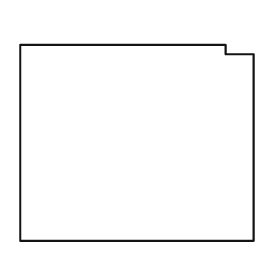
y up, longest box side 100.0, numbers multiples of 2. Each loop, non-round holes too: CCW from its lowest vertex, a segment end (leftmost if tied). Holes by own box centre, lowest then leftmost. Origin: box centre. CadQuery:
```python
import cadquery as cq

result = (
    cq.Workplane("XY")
    .moveTo(-50.0, -42.0)
    .lineTo(50.0, -42.0)
    .lineTo(50.0, 38.0)
    .lineTo(38.0, 38.0)
    .lineTo(38.0, 42.0)
    .lineTo(-50.0, 42.0)
    .close()
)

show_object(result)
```